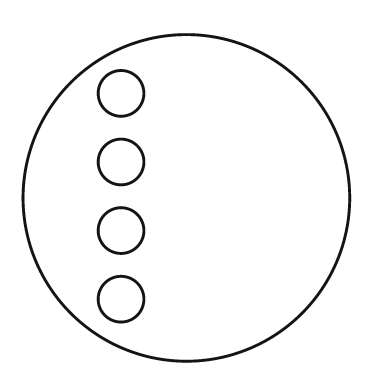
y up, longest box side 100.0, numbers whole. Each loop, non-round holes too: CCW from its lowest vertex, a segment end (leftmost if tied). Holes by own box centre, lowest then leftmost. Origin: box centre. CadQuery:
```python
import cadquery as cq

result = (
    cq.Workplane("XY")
    .moveTo(0.0, 0.0)
    .circle(50.0)
    .moveTo(-20.0, -31.0)
    .circle(7.0)
    .moveTo(-20.0, -10.0)
    .circle(7.0)
    .moveTo(-20.0, 11.0)
    .circle(7.0)
    .moveTo(-20.0, 32.0)
    .circle(7.0)
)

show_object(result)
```